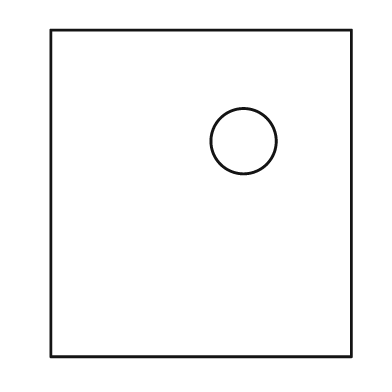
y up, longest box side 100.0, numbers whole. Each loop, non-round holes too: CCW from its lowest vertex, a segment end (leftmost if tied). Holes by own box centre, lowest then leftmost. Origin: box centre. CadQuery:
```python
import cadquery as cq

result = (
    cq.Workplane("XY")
    .moveTo(-46.0, -50.0)
    .lineTo(46.0, -50.0)
    .lineTo(46.0, 50.0)
    .lineTo(-46.0, 50.0)
    .close()
    .moveTo(13.0, 16.0)
    .circle(10.0)
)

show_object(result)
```